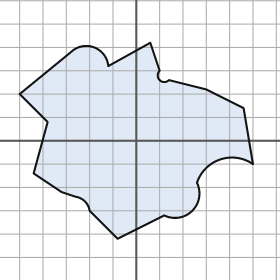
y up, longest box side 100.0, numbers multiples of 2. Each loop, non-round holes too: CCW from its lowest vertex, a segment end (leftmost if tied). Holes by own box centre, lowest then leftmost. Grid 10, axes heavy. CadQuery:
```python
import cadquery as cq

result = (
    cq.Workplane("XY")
    .moveTo(-8.0, -42.0)
    .lineTo(12.0, -32.0)
    .threePointArc((24.0, -30.0), (26.0, -18.0))
    .threePointArc((36.0, -8.0), (50.0, -10.0))
    .lineTo(46.0, 14.0)
    .lineTo(30.0, 22.0)
    .lineTo(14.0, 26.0)
    .threePointArc((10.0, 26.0), (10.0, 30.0))
    .lineTo(6.0, 42.0)
    .lineTo(-12.0, 32.0)
    .threePointArc((-18.0, 40.0), (-28.0, 38.0))
    .lineTo(-50.0, 20.0)
    .lineTo(-38.0, 8.0)
    .lineTo(-44.0, -14.0)
    .lineTo(-32.0, -22.0)
    .lineTo(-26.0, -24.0)
    .threePointArc((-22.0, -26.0), (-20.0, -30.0))
    .close()
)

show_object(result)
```